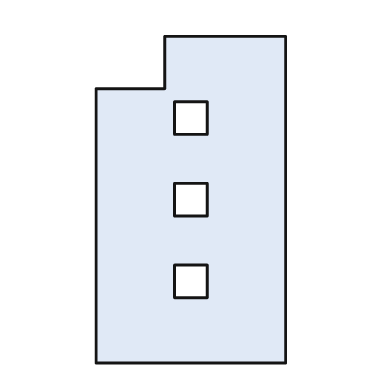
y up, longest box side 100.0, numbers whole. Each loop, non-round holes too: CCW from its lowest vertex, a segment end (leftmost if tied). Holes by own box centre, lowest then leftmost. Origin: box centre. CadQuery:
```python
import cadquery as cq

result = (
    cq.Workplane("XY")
    .moveTo(-29.0, -50.0)
    .lineTo(29.0, -50.0)
    .lineTo(29.0, 50.0)
    .lineTo(-8.0, 50.0)
    .lineTo(-8.0, 34.0)
    .lineTo(-29.0, 34.0)
    .close()
    .moveTo(-5.0, -30.0)
    .lineTo(5.0, -30.0)
    .lineTo(5.0, -20.0)
    .lineTo(-5.0, -20.0)
    .close()
    .moveTo(-5.0, -5.0)
    .lineTo(5.0, -5.0)
    .lineTo(5.0, 5.0)
    .lineTo(-5.0, 5.0)
    .close()
    .moveTo(-5.0, 20.0)
    .lineTo(5.0, 20.0)
    .lineTo(5.0, 30.0)
    .lineTo(-5.0, 30.0)
    .close()
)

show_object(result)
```